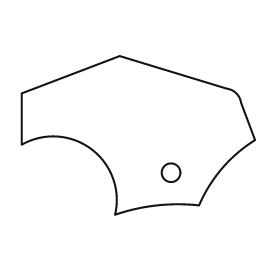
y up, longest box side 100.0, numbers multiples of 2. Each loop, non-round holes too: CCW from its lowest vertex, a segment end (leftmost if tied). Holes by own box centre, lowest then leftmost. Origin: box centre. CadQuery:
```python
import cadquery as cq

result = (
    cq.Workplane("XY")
    .moveTo(-10.0, -34.0)
    .threePointArc((8.0, -30.0), (26.0, -30.0))
    .threePointArc((36.0, -14.0), (50.0, -2.0))
    .lineTo(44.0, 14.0)
    .threePointArc((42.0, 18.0), (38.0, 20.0))
    .lineTo(-8.0, 34.0)
    .lineTo(-50.0, 18.0)
    .lineTo(-50.0, -4.0)
    .threePointArc((-20.0, -6.0), (-10.0, -34.0))
    .close()
    .moveTo(14.0, -16.0)
    .circle(4.0)
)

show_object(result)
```